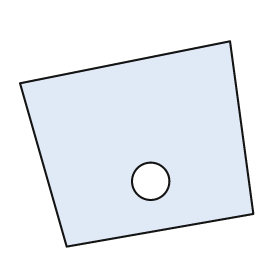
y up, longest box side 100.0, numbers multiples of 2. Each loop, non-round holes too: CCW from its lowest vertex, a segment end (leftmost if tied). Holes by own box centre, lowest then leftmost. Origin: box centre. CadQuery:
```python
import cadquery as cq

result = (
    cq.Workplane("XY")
    .moveTo(-30.0, -44.0)
    .lineTo(50.0, -30.0)
    .lineTo(40.0, 44.0)
    .lineTo(-50.0, 26.0)
    .close()
    .moveTo(6.0, -16.0)
    .circle(8.0)
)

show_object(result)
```